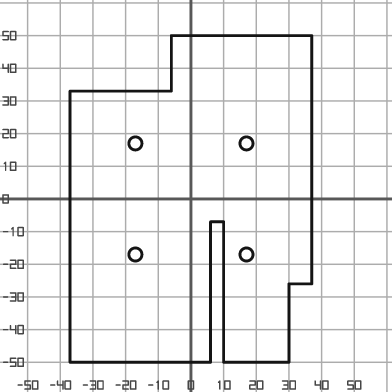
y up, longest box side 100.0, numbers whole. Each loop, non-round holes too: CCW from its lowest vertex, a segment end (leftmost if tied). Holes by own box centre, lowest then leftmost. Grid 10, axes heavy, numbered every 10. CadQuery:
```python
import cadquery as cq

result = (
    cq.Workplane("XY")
    .moveTo(-37.0, -50.0)
    .lineTo(6.0, -50.0)
    .lineTo(6.0, -7.0)
    .lineTo(10.0, -7.0)
    .lineTo(10.0, -50.0)
    .lineTo(30.0, -50.0)
    .lineTo(30.0, -26.0)
    .lineTo(37.0, -26.0)
    .lineTo(37.0, 50.0)
    .lineTo(-6.0, 50.0)
    .lineTo(-6.0, 33.0)
    .lineTo(-37.0, 33.0)
    .close()
    .moveTo(-17.0, -17.0)
    .circle(2.0)
    .moveTo(17.0, -17.0)
    .circle(2.0)
    .moveTo(-17.0, 17.0)
    .circle(2.0)
    .moveTo(17.0, 17.0)
    .circle(2.0)
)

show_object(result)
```